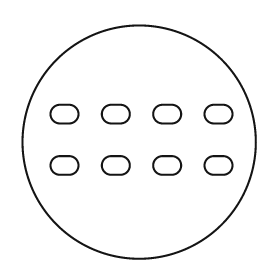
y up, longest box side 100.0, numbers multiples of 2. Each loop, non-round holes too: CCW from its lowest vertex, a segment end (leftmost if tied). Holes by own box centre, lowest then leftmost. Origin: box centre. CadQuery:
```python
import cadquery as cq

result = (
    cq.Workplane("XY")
    .moveTo(0.0, 0.0)
    .circle(50.0)
    .moveTo(-34.0, -14.0)
    .lineTo(-30.0, -14.0)
    .threePointArc((-26.0, -10.0), (-30.0, -6.0))
    .lineTo(-34.0, -6.0)
    .threePointArc((-38.0, -10.0), (-34.0, -14.0))
    .close()
    .moveTo(-12.0, -14.0)
    .lineTo(-8.0, -14.0)
    .threePointArc((-4.0, -10.0), (-8.0, -6.0))
    .lineTo(-12.0, -6.0)
    .threePointArc((-16.0, -10.0), (-12.0, -14.0))
    .close()
    .moveTo(10.0, -14.0)
    .lineTo(14.0, -14.0)
    .threePointArc((18.0, -10.0), (14.0, -6.0))
    .lineTo(10.0, -6.0)
    .threePointArc((6.0, -10.0), (10.0, -14.0))
    .close()
    .moveTo(32.0, -14.0)
    .lineTo(36.0, -14.0)
    .threePointArc((40.0, -10.0), (36.0, -6.0))
    .lineTo(32.0, -6.0)
    .threePointArc((28.0, -10.0), (32.0, -14.0))
    .close()
    .moveTo(-34.0, 8.0)
    .lineTo(-30.0, 8.0)
    .threePointArc((-26.0, 12.0), (-30.0, 16.0))
    .lineTo(-34.0, 16.0)
    .threePointArc((-38.0, 12.0), (-34.0, 8.0))
    .close()
    .moveTo(-12.0, 8.0)
    .lineTo(-8.0, 8.0)
    .threePointArc((-4.0, 12.0), (-8.0, 16.0))
    .lineTo(-12.0, 16.0)
    .threePointArc((-16.0, 12.0), (-12.0, 8.0))
    .close()
    .moveTo(10.0, 8.0)
    .lineTo(14.0, 8.0)
    .threePointArc((18.0, 12.0), (14.0, 16.0))
    .lineTo(10.0, 16.0)
    .threePointArc((6.0, 12.0), (10.0, 8.0))
    .close()
    .moveTo(32.0, 8.0)
    .lineTo(36.0, 8.0)
    .threePointArc((40.0, 12.0), (36.0, 16.0))
    .lineTo(32.0, 16.0)
    .threePointArc((28.0, 12.0), (32.0, 8.0))
    .close()
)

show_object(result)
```